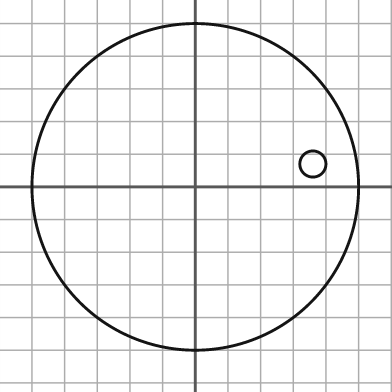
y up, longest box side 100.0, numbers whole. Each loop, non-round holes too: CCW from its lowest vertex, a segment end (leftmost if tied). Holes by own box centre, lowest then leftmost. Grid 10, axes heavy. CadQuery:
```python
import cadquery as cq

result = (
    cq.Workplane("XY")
    .moveTo(0.0, 0.0)
    .circle(50.0)
    .moveTo(36.0, 7.0)
    .circle(4.0)
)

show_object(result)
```